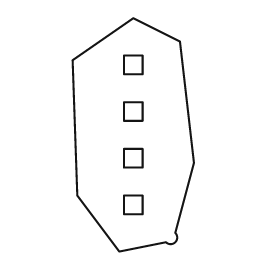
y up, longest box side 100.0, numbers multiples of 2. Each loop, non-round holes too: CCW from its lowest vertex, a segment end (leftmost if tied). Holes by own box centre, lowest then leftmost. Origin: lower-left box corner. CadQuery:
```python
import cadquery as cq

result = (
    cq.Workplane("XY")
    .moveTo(20.0, 0.0)
    .lineTo(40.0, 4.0)
    .threePointArc((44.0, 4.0), (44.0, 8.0))
    .lineTo(52.0, 38.0)
    .lineTo(46.0, 90.0)
    .lineTo(26.0, 100.0)
    .lineTo(0.0, 82.0)
    .lineTo(2.0, 24.0)
    .close()
    .moveTo(22.0, 16.0)
    .lineTo(30.0, 16.0)
    .lineTo(30.0, 24.0)
    .lineTo(22.0, 24.0)
    .close()
    .moveTo(22.0, 36.0)
    .lineTo(30.0, 36.0)
    .lineTo(30.0, 44.0)
    .lineTo(22.0, 44.0)
    .close()
    .moveTo(22.0, 56.0)
    .lineTo(30.0, 56.0)
    .lineTo(30.0, 64.0)
    .lineTo(22.0, 64.0)
    .close()
    .moveTo(22.0, 76.0)
    .lineTo(30.0, 76.0)
    .lineTo(30.0, 84.0)
    .lineTo(22.0, 84.0)
    .close()
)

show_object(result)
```